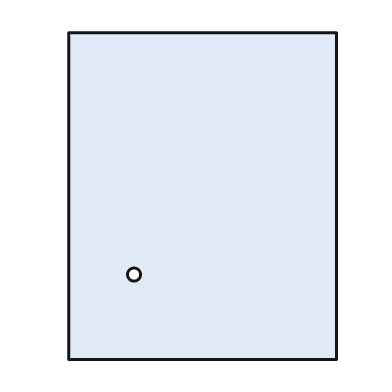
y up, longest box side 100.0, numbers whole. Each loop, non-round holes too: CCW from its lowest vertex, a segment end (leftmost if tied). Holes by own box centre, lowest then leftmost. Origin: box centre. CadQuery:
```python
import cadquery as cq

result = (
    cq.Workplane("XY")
    .moveTo(-41.0, -50.0)
    .lineTo(41.0, -50.0)
    .lineTo(41.0, 50.0)
    .lineTo(-41.0, 50.0)
    .close()
    .moveTo(-21.0, -24.0)
    .circle(2.0)
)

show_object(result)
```